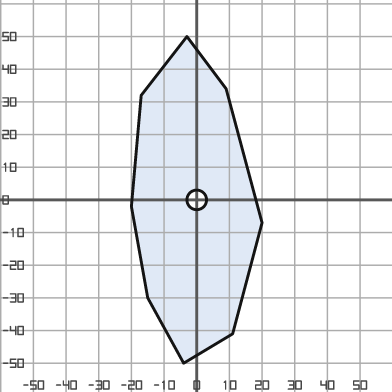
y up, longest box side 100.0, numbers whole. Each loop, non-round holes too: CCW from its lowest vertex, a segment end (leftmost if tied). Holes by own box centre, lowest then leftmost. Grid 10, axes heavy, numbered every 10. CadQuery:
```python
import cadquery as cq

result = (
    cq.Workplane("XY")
    .moveTo(-4.0, -50.0)
    .lineTo(11.0, -41.0)
    .lineTo(20.0, -7.0)
    .lineTo(9.0, 34.0)
    .lineTo(-3.0, 50.0)
    .lineTo(-17.0, 32.0)
    .lineTo(-20.0, -2.0)
    .lineTo(-15.0, -30.0)
    .close()
    .moveTo(0.0, 0.0)
    .circle(3.0)
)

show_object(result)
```